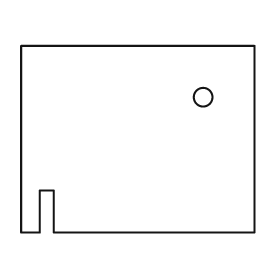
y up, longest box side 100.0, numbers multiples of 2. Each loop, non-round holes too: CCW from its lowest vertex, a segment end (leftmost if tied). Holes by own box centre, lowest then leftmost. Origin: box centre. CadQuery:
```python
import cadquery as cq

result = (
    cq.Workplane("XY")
    .moveTo(-50.0, -40.0)
    .lineTo(-42.0, -40.0)
    .lineTo(-42.0, -22.0)
    .lineTo(-36.0, -22.0)
    .lineTo(-36.0, -40.0)
    .lineTo(50.0, -40.0)
    .lineTo(50.0, 40.0)
    .lineTo(-50.0, 40.0)
    .close()
    .moveTo(28.0, 18.0)
    .circle(4.0)
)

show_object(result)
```